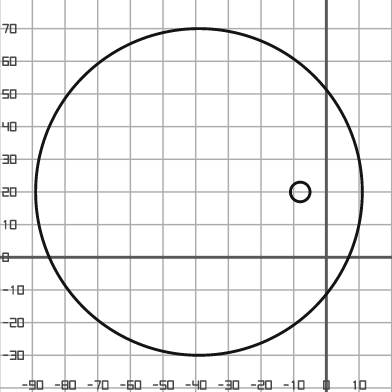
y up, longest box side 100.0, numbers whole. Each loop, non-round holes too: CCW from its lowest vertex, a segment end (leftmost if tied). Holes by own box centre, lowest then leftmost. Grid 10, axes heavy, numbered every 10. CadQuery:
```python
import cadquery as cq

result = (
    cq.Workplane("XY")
    .moveTo(-39.0, 20.0)
    .circle(50.0)
    .moveTo(-8.0, 20.0)
    .circle(3.0)
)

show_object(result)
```